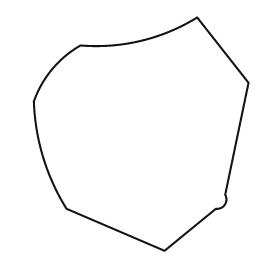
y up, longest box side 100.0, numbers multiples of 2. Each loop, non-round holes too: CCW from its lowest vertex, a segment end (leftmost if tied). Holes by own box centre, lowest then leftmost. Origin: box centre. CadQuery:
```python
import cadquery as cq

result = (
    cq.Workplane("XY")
    .moveTo(10.0, -50.0)
    .lineTo(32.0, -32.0)
    .threePointArc((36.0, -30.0), (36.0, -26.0))
    .lineTo(46.0, 22.0)
    .lineTo(24.0, 50.0)
    .threePointArc((0.0, 40.0), (-26.0, 38.0))
    .threePointArc((-38.0, 28.0), (-46.0, 14.0))
    .threePointArc((-42.0, -10.0), (-32.0, -32.0))
    .close()
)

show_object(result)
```